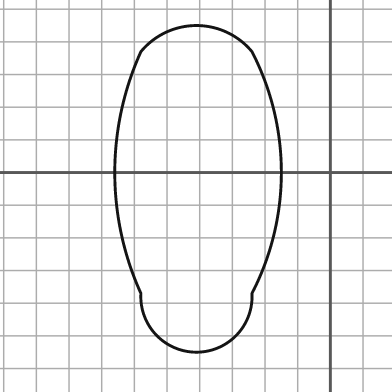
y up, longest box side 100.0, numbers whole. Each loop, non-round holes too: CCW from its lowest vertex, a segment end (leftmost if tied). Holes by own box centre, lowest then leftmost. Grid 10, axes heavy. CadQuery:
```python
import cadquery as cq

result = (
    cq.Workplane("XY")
    .moveTo(-58.0, -37.0)
    .threePointArc((-41.0, -55.0), (-24.0, -37.0))
    .threePointArc((-15.0, 0.0), (-24.0, 37.0))
    .threePointArc((-41.0, 45.0), (-58.0, 37.0))
    .threePointArc((-66.0, 0.0), (-58.0, -37.0))
    .close()
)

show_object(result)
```